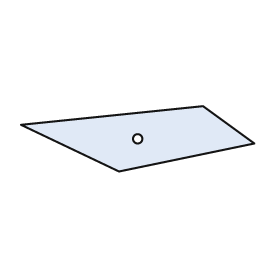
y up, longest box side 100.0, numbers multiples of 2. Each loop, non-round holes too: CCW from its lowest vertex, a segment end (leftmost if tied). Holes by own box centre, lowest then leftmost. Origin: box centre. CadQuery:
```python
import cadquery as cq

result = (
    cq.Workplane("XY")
    .moveTo(-8.0, -14.0)
    .lineTo(50.0, -2.0)
    .lineTo(28.0, 14.0)
    .lineTo(-50.0, 6.0)
    .close()
    .moveTo(0.0, 0.0)
    .circle(2.0)
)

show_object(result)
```